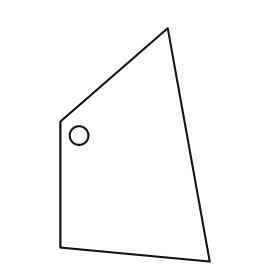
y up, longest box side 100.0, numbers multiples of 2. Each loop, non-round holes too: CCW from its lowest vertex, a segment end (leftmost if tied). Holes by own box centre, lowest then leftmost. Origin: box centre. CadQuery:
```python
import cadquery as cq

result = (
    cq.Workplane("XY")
    .moveTo(32.0, -50.0)
    .lineTo(14.0, 50.0)
    .lineTo(-32.0, 10.0)
    .lineTo(-32.0, -44.0)
    .close()
    .moveTo(-24.0, 4.0)
    .circle(4.0)
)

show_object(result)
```